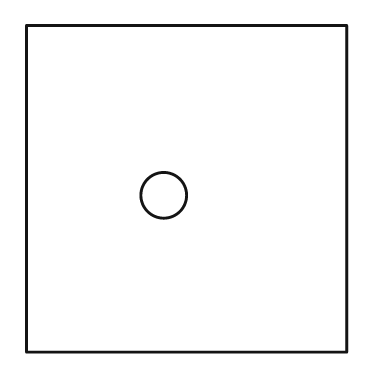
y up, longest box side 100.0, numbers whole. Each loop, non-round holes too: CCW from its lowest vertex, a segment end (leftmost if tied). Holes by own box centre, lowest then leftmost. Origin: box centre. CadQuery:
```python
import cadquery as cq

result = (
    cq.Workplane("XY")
    .moveTo(-49.0, -50.0)
    .lineTo(49.0, -50.0)
    .lineTo(49.0, 50.0)
    .lineTo(-49.0, 50.0)
    .close()
    .moveTo(-7.0, -2.0)
    .circle(7.0)
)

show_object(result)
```